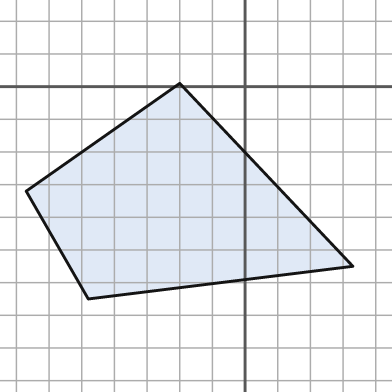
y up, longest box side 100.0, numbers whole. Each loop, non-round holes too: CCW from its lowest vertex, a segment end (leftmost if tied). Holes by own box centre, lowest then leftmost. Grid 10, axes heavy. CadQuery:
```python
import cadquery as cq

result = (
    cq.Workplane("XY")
    .moveTo(-48.0, -65.0)
    .lineTo(33.0, -55.0)
    .lineTo(-20.0, 1.0)
    .lineTo(-67.0, -32.0)
    .close()
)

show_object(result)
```